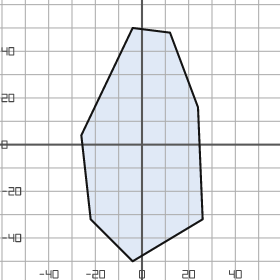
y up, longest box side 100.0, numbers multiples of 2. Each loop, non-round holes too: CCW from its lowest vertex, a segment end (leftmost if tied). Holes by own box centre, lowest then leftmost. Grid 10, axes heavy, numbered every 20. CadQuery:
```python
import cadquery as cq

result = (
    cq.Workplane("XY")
    .moveTo(-4.0, -50.0)
    .lineTo(26.0, -32.0)
    .lineTo(24.0, 16.0)
    .lineTo(12.0, 48.0)
    .lineTo(-4.0, 50.0)
    .lineTo(-26.0, 4.0)
    .lineTo(-22.0, -32.0)
    .close()
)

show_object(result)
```